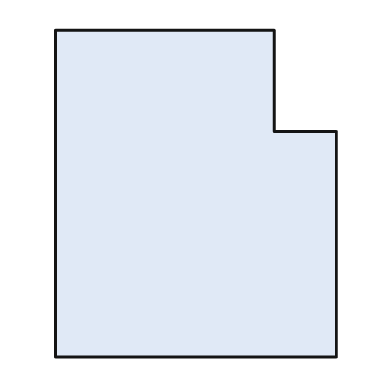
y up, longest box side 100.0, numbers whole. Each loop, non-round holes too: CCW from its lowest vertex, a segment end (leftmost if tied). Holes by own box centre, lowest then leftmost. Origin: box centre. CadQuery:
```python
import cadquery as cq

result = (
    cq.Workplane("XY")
    .moveTo(-43.0, -50.0)
    .lineTo(43.0, -50.0)
    .lineTo(43.0, 19.0)
    .lineTo(24.0, 19.0)
    .lineTo(24.0, 50.0)
    .lineTo(-43.0, 50.0)
    .close()
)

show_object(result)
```